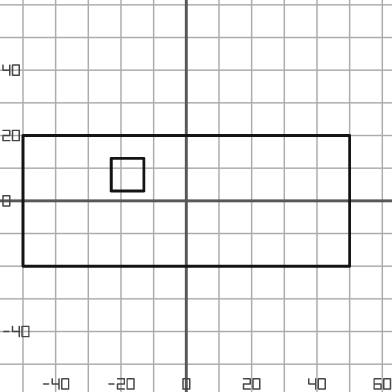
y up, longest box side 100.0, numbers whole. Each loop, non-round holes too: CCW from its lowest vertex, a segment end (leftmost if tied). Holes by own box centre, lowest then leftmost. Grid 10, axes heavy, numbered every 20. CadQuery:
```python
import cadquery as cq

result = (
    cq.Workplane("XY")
    .moveTo(-50.0, -20.0)
    .lineTo(50.0, -20.0)
    .lineTo(50.0, 20.0)
    .lineTo(-50.0, 20.0)
    .close()
    .moveTo(-23.0, 3.0)
    .lineTo(-13.0, 3.0)
    .lineTo(-13.0, 13.0)
    .lineTo(-23.0, 13.0)
    .close()
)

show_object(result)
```